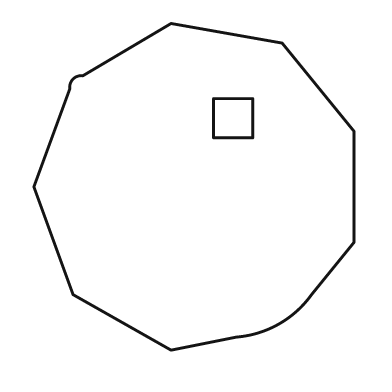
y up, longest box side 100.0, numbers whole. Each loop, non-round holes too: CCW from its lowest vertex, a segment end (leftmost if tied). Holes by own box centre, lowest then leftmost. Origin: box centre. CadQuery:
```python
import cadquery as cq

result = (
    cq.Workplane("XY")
    .moveTo(-7.0, -50.0)
    .lineTo(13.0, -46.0)
    .threePointArc((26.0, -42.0), (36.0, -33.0))
    .lineTo(49.0, -17.0)
    .lineTo(49.0, 17.0)
    .lineTo(27.0, 44.0)
    .lineTo(-7.0, 50.0)
    .lineTo(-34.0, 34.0)
    .threePointArc((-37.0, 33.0), (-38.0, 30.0))
    .lineTo(-49.0, 0.0)
    .lineTo(-37.0, -33.0)
    .close()
    .moveTo(6.0, 15.0)
    .lineTo(18.0, 15.0)
    .lineTo(18.0, 27.0)
    .lineTo(6.0, 27.0)
    .close()
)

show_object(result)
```